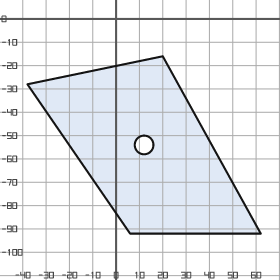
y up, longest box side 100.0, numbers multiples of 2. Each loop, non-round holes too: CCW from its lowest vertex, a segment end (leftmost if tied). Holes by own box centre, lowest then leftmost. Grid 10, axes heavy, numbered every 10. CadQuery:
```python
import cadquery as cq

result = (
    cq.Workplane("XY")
    .moveTo(6.0, -92.0)
    .lineTo(62.0, -92.0)
    .lineTo(20.0, -16.0)
    .lineTo(-38.0, -28.0)
    .close()
    .moveTo(12.0, -54.0)
    .circle(4.0)
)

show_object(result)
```